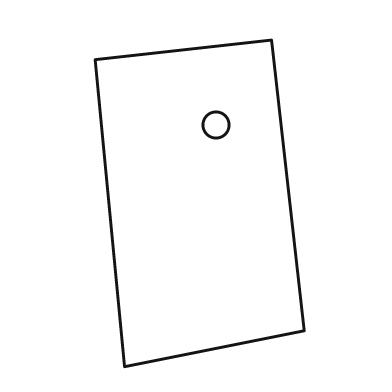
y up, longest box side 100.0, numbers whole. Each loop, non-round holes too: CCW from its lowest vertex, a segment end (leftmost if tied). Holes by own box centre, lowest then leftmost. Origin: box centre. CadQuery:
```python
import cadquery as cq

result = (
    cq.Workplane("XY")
    .moveTo(-23.0, -50.0)
    .lineTo(32.0, -39.0)
    .lineTo(22.0, 50.0)
    .lineTo(-32.0, 44.0)
    .close()
    .moveTo(5.0, 24.0)
    .circle(4.0)
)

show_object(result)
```